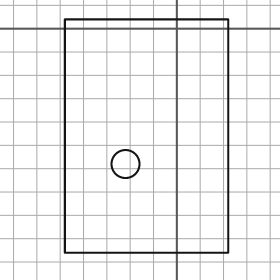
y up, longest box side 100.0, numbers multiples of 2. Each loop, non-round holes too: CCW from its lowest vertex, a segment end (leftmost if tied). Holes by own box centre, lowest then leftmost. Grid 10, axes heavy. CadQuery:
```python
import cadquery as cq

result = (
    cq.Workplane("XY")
    .moveTo(-48.0, -96.0)
    .lineTo(22.0, -96.0)
    .lineTo(22.0, 4.0)
    .lineTo(-48.0, 4.0)
    .close()
    .moveTo(-22.0, -58.0)
    .circle(6.0)
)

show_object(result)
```